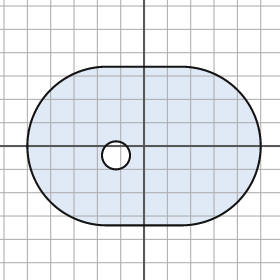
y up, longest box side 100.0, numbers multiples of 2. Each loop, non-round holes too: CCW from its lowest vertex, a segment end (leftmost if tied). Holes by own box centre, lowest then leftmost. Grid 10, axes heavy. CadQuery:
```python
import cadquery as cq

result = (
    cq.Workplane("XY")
    .moveTo(-16.0, -34.0)
    .lineTo(16.0, -34.0)
    .threePointArc((50.0, 0.0), (16.0, 34.0))
    .lineTo(-16.0, 34.0)
    .threePointArc((-50.0, 0.0), (-16.0, -34.0))
    .close()
    .moveTo(-12.0, -4.0)
    .circle(6.0)
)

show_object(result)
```